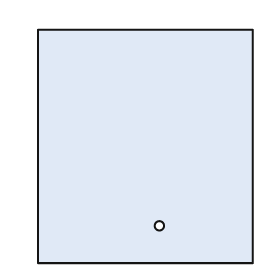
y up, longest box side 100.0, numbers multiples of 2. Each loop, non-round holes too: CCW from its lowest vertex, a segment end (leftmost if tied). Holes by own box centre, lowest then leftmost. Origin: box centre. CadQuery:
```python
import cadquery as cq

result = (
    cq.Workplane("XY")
    .moveTo(-46.0, -50.0)
    .lineTo(46.0, -50.0)
    .lineTo(46.0, 50.0)
    .lineTo(-46.0, 50.0)
    .close()
    .moveTo(6.0, -34.0)
    .circle(2.0)
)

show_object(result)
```